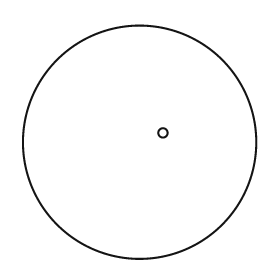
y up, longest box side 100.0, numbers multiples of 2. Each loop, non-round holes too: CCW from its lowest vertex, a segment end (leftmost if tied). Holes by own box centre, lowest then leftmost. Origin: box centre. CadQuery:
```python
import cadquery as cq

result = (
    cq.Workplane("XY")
    .moveTo(0.0, 0.0)
    .circle(50.0)
    .moveTo(10.0, 4.0)
    .circle(2.0)
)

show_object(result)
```